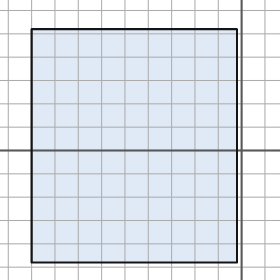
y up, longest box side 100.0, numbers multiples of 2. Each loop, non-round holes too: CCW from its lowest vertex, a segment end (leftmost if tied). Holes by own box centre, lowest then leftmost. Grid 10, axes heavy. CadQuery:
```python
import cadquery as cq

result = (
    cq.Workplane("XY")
    .moveTo(-90.0, -48.0)
    .lineTo(-2.0, -48.0)
    .lineTo(-2.0, 52.0)
    .lineTo(-90.0, 52.0)
    .close()
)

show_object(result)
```